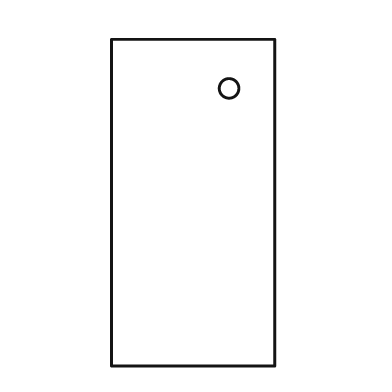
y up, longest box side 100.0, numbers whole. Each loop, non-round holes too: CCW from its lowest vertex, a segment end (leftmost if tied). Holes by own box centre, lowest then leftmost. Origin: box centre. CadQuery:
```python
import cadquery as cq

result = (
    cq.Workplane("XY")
    .moveTo(-25.0, -50.0)
    .lineTo(25.0, -50.0)
    .lineTo(25.0, 50.0)
    .lineTo(-25.0, 50.0)
    .close()
    .moveTo(11.0, 35.0)
    .circle(3.0)
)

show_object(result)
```